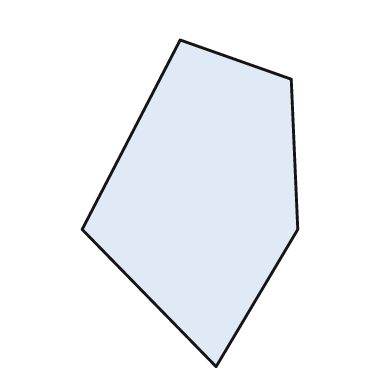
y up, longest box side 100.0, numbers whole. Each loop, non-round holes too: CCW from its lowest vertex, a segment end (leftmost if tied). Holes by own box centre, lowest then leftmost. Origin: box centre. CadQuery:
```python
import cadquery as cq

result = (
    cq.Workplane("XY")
    .moveTo(8.0, -50.0)
    .lineTo(33.0, -8.0)
    .lineTo(31.0, 38.0)
    .lineTo(-3.0, 50.0)
    .lineTo(-33.0, -8.0)
    .close()
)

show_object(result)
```